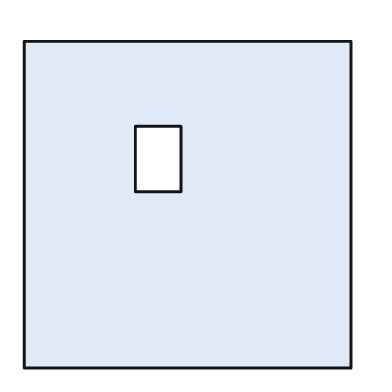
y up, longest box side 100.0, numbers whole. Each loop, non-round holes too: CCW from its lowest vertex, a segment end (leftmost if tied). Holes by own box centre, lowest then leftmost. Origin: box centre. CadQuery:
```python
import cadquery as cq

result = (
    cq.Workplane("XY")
    .moveTo(-50.0, -50.0)
    .lineTo(50.0, -50.0)
    .lineTo(50.0, 50.0)
    .lineTo(-50.0, 50.0)
    .close()
    .moveTo(-16.0, 4.0)
    .lineTo(-2.0, 4.0)
    .lineTo(-2.0, 24.0)
    .lineTo(-16.0, 24.0)
    .close()
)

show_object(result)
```